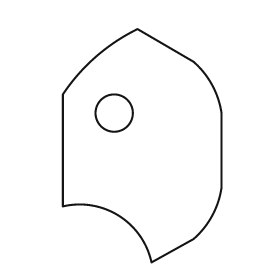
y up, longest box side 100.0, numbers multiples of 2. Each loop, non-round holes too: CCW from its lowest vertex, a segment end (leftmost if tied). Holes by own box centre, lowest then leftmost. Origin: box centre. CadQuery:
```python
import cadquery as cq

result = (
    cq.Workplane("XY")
    .moveTo(4.0, -50.0)
    .lineTo(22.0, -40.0)
    .threePointArc((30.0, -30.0), (34.0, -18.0))
    .lineTo(34.0, 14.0)
    .threePointArc((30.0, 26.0), (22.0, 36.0))
    .lineTo(-2.0, 50.0)
    .threePointArc((-20.0, 38.0), (-34.0, 22.0))
    .lineTo(-34.0, -26.0)
    .threePointArc((-10.0, -30.0), (4.0, -50.0))
    .close()
    .moveTo(-12.0, 14.0)
    .circle(8.0)
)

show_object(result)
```